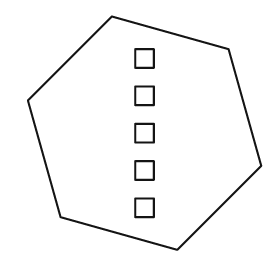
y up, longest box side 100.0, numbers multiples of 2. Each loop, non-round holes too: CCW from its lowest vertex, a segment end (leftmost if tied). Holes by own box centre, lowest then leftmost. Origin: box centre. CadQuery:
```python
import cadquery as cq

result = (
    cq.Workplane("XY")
    .moveTo(14.0, -50.0)
    .lineTo(50.0, -14.0)
    .lineTo(36.0, 36.0)
    .lineTo(-14.0, 50.0)
    .lineTo(-50.0, 14.0)
    .lineTo(-36.0, -36.0)
    .close()
    .moveTo(-4.0, -36.0)
    .lineTo(4.0, -36.0)
    .lineTo(4.0, -28.0)
    .lineTo(-4.0, -28.0)
    .close()
    .moveTo(-4.0, -20.0)
    .lineTo(4.0, -20.0)
    .lineTo(4.0, -12.0)
    .lineTo(-4.0, -12.0)
    .close()
    .moveTo(-4.0, -4.0)
    .lineTo(4.0, -4.0)
    .lineTo(4.0, 4.0)
    .lineTo(-4.0, 4.0)
    .close()
    .moveTo(-4.0, 12.0)
    .lineTo(4.0, 12.0)
    .lineTo(4.0, 20.0)
    .lineTo(-4.0, 20.0)
    .close()
    .moveTo(-4.0, 28.0)
    .lineTo(4.0, 28.0)
    .lineTo(4.0, 36.0)
    .lineTo(-4.0, 36.0)
    .close()
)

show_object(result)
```